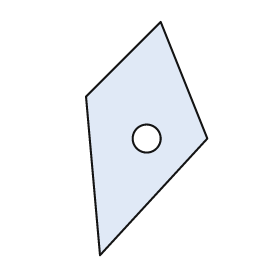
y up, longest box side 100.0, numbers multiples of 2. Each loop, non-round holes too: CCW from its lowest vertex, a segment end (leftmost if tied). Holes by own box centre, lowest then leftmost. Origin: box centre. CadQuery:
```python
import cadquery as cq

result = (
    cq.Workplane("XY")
    .moveTo(-20.0, -50.0)
    .lineTo(26.0, 0.0)
    .lineTo(6.0, 50.0)
    .lineTo(-26.0, 18.0)
    .close()
    .moveTo(0.0, 0.0)
    .circle(6.0)
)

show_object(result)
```